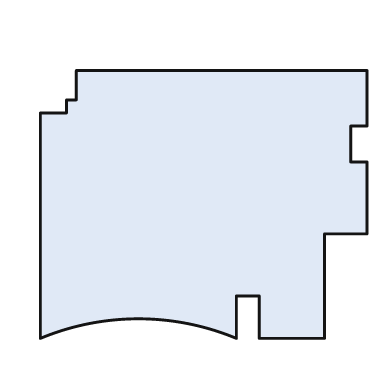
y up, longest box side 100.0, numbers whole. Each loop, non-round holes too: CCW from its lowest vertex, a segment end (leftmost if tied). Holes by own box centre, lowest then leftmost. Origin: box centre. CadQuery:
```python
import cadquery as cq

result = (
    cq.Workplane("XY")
    .moveTo(-50.0, -41.0)
    .threePointArc((-20.0, -35.0), (10.0, -41.0))
    .lineTo(10.0, -28.0)
    .lineTo(17.0, -28.0)
    .lineTo(17.0, -41.0)
    .lineTo(37.0, -41.0)
    .lineTo(37.0, -9.0)
    .lineTo(50.0, -9.0)
    .lineTo(50.0, 13.0)
    .lineTo(45.0, 13.0)
    .lineTo(45.0, 24.0)
    .lineTo(50.0, 24.0)
    .lineTo(50.0, 41.0)
    .lineTo(-39.0, 41.0)
    .lineTo(-39.0, 32.0)
    .lineTo(-42.0, 32.0)
    .lineTo(-42.0, 28.0)
    .lineTo(-50.0, 28.0)
    .close()
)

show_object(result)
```